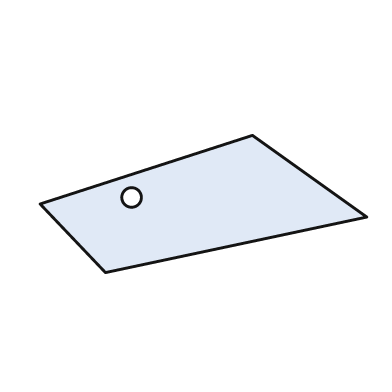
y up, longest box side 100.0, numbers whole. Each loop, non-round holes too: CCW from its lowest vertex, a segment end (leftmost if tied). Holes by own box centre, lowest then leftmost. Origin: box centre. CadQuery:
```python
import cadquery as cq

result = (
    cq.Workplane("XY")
    .moveTo(-30.0, -21.0)
    .lineTo(50.0, -4.0)
    .lineTo(15.0, 21.0)
    .lineTo(-50.0, 0.0)
    .close()
    .moveTo(-22.0, 2.0)
    .circle(3.0)
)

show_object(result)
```